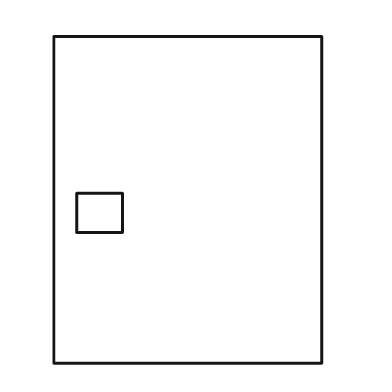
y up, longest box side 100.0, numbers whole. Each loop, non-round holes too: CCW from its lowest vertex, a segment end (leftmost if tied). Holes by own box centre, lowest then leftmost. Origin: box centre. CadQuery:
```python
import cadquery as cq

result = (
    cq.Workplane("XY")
    .moveTo(-41.0, -50.0)
    .lineTo(41.0, -50.0)
    .lineTo(41.0, 50.0)
    .lineTo(-41.0, 50.0)
    .close()
    .moveTo(-34.0, -10.0)
    .lineTo(-20.0, -10.0)
    .lineTo(-20.0, 2.0)
    .lineTo(-34.0, 2.0)
    .close()
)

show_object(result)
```